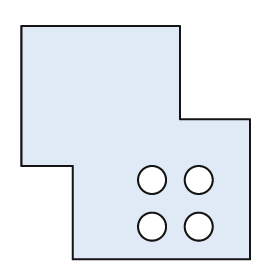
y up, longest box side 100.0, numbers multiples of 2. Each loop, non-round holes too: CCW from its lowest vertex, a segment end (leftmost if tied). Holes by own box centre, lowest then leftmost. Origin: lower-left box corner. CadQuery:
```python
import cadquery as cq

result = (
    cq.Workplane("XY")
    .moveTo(22.0, 0.0)
    .lineTo(98.0, 0.0)
    .lineTo(98.0, 60.0)
    .lineTo(68.0, 60.0)
    .lineTo(68.0, 100.0)
    .lineTo(0.0, 100.0)
    .lineTo(0.0, 40.0)
    .lineTo(22.0, 40.0)
    .close()
    .moveTo(56.0, 14.0)
    .circle(6.0)
    .moveTo(76.0, 14.0)
    .circle(6.0)
    .moveTo(56.0, 34.0)
    .circle(6.0)
    .moveTo(76.0, 34.0)
    .circle(6.0)
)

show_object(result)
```